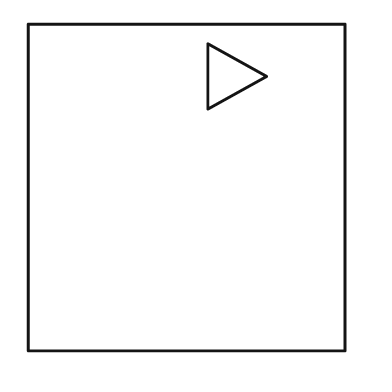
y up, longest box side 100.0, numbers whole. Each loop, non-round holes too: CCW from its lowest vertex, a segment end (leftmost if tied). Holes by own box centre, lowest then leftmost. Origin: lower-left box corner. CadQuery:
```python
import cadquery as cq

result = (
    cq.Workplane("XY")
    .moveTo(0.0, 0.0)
    .lineTo(97.0, 0.0)
    .lineTo(97.0, 100.0)
    .lineTo(0.0, 100.0)
    .close()
    .moveTo(55.0, 74.0)
    .lineTo(73.0, 84.0)
    .lineTo(55.0, 94.0)
    .close()
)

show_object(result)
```